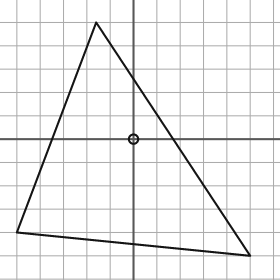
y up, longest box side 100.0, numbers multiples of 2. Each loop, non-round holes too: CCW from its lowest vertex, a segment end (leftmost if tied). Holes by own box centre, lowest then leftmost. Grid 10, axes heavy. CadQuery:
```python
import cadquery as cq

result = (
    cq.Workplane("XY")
    .moveTo(50.0, -50.0)
    .lineTo(-16.0, 50.0)
    .lineTo(-50.0, -40.0)
    .close()
    .moveTo(0.0, 0.0)
    .circle(2.0)
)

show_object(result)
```